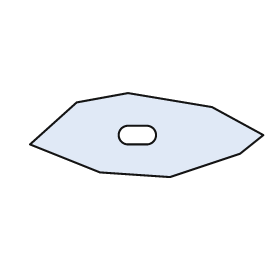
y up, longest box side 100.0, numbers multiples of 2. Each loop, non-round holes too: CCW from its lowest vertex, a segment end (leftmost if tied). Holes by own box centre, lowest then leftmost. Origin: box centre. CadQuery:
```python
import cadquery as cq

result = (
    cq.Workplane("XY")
    .moveTo(10.0, -18.0)
    .lineTo(40.0, -8.0)
    .lineTo(50.0, 0.0)
    .lineTo(28.0, 12.0)
    .lineTo(-8.0, 18.0)
    .lineTo(-30.0, 14.0)
    .lineTo(-50.0, -4.0)
    .lineTo(-20.0, -16.0)
    .close()
    .moveTo(-8.0, -4.0)
    .lineTo(0.0, -4.0)
    .threePointArc((4.0, 0.0), (0.0, 4.0))
    .lineTo(-8.0, 4.0)
    .threePointArc((-12.0, 0.0), (-8.0, -4.0))
    .close()
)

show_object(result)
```